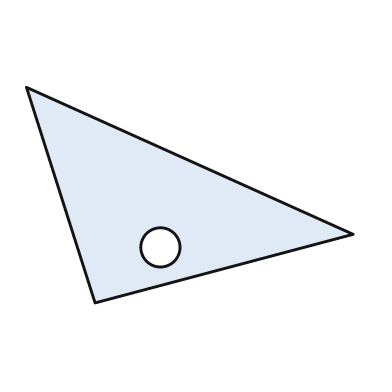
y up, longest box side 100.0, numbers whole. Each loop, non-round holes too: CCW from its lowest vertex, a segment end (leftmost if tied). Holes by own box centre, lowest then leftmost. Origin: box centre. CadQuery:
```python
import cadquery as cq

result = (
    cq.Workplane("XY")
    .moveTo(-29.0, -33.0)
    .lineTo(50.0, -12.0)
    .lineTo(-50.0, 33.0)
    .close()
    .moveTo(-9.0, -16.0)
    .circle(6.0)
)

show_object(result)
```